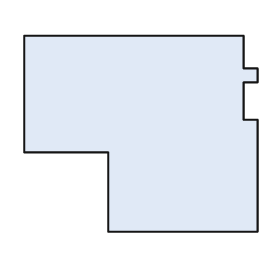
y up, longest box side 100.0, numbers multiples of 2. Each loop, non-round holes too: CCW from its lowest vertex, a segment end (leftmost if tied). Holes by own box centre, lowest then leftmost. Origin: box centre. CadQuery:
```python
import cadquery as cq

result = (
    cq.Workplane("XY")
    .moveTo(-14.0, -42.0)
    .lineTo(50.0, -42.0)
    .lineTo(50.0, 6.0)
    .lineTo(44.0, 6.0)
    .lineTo(44.0, 22.0)
    .lineTo(50.0, 22.0)
    .lineTo(50.0, 28.0)
    .lineTo(44.0, 28.0)
    .lineTo(44.0, 42.0)
    .lineTo(-50.0, 42.0)
    .lineTo(-50.0, -8.0)
    .lineTo(-14.0, -8.0)
    .close()
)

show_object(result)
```